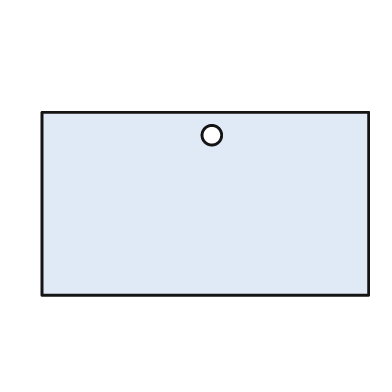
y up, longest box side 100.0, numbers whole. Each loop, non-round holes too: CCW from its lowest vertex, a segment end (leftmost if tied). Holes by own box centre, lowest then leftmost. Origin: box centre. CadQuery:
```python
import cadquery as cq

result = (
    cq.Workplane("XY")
    .moveTo(-50.0, -28.0)
    .lineTo(50.0, -28.0)
    .lineTo(50.0, 28.0)
    .lineTo(-50.0, 28.0)
    .close()
    .moveTo(2.0, 21.0)
    .circle(3.0)
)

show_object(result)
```